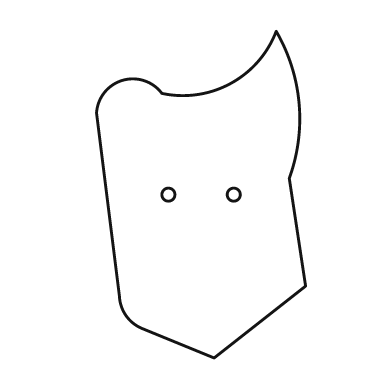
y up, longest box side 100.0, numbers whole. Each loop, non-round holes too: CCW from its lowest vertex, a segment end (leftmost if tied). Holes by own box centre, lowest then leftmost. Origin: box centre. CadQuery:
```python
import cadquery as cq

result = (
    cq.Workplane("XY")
    .moveTo(4.0, -50.0)
    .lineTo(32.0, -28.0)
    .lineTo(27.0, 5.0)
    .threePointArc((30.0, 28.0), (23.0, 50.0))
    .threePointArc((9.0, 34.0), (-12.0, 31.0))
    .threePointArc((-24.0, 35.0), (-32.0, 25.0))
    .lineTo(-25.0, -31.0)
    .threePointArc((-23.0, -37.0), (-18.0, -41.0))
    .close()
    .moveTo(-10.0, 0.0)
    .circle(2.0)
    .moveTo(10.0, 0.0)
    .circle(2.0)
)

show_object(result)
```